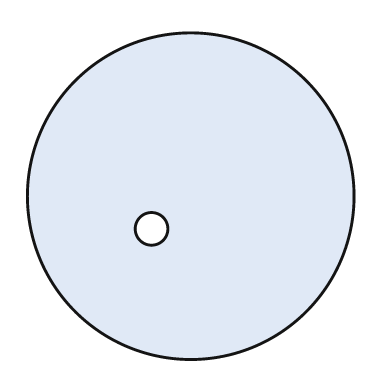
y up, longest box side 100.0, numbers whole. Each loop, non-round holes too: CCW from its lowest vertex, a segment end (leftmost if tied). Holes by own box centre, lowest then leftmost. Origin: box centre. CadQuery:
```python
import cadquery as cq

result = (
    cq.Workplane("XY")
    .moveTo(0.0, 0.0)
    .circle(50.0)
    .moveTo(-12.0, -10.0)
    .circle(5.0)
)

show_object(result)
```